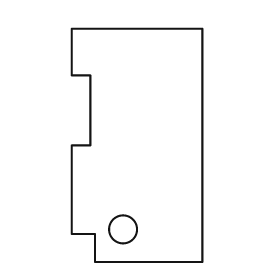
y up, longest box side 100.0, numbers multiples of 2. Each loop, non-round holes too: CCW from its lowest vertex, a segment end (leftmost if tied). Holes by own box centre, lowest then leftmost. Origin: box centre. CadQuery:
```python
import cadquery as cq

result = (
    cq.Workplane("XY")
    .moveTo(-18.0, -50.0)
    .lineTo(28.0, -50.0)
    .lineTo(28.0, 50.0)
    .lineTo(-28.0, 50.0)
    .lineTo(-28.0, 30.0)
    .lineTo(-20.0, 30.0)
    .lineTo(-20.0, 0.0)
    .lineTo(-28.0, 0.0)
    .lineTo(-28.0, -38.0)
    .lineTo(-18.0, -38.0)
    .close()
    .moveTo(-6.0, -36.0)
    .circle(6.0)
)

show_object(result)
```